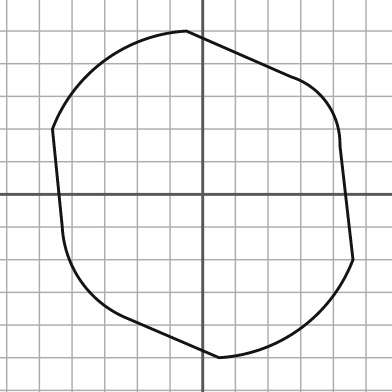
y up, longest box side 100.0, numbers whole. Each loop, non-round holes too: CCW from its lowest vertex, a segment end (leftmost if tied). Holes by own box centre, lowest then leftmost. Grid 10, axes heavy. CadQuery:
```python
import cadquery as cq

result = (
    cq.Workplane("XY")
    .moveTo(5.0, -50.0)
    .threePointArc((30.0, -41.0), (46.0, -20.0))
    .lineTo(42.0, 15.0)
    .threePointArc((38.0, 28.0), (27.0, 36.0))
    .lineTo(-5.0, 50.0)
    .threePointArc((-30.0, 41.0), (-46.0, 20.0))
    .lineTo(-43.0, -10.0)
    .threePointArc((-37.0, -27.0), (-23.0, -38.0))
    .close()
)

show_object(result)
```